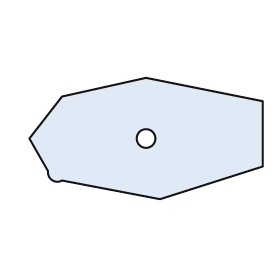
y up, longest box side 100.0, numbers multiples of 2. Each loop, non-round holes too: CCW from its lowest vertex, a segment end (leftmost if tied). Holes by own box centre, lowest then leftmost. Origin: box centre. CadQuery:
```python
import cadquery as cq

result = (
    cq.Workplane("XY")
    .moveTo(6.0, -26.0)
    .lineTo(50.0, -12.0)
    .lineTo(50.0, 16.0)
    .lineTo(0.0, 26.0)
    .lineTo(-36.0, 18.0)
    .lineTo(-50.0, 0.0)
    .lineTo(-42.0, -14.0)
    .threePointArc((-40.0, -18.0), (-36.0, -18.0))
    .close()
    .moveTo(0.0, 0.0)
    .circle(4.0)
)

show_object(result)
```